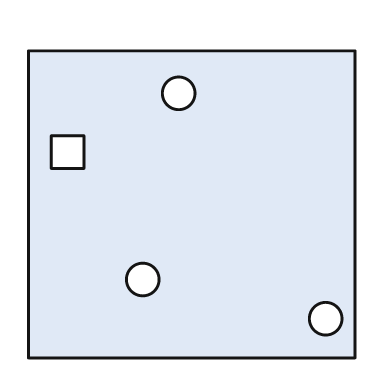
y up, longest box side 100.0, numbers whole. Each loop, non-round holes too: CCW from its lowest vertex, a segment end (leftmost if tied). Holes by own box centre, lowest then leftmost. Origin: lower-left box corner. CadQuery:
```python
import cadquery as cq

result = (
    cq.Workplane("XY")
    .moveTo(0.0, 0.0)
    .lineTo(100.0, 0.0)
    .lineTo(100.0, 94.0)
    .lineTo(0.0, 94.0)
    .close()
    .moveTo(91.0, 12.0)
    .circle(5.0)
    .moveTo(35.0, 24.0)
    .circle(5.0)
    .moveTo(7.0, 58.0)
    .lineTo(17.0, 58.0)
    .lineTo(17.0, 68.0)
    .lineTo(7.0, 68.0)
    .close()
    .moveTo(46.0, 81.0)
    .circle(5.0)
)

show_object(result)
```